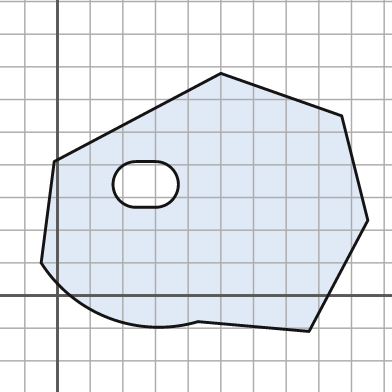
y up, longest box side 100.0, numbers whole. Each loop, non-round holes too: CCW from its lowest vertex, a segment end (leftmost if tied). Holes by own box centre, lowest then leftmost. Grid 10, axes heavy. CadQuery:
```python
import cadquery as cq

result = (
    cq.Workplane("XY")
    .moveTo(77.0, -11.0)
    .lineTo(95.0, 23.0)
    .lineTo(87.0, 55.0)
    .lineTo(50.0, 68.0)
    .lineTo(-1.0, 41.0)
    .lineTo(-5.0, 10.0)
    .threePointArc((16.0, -7.0), (43.0, -8.0))
    .close()
    .moveTo(24.0, 27.0)
    .lineTo(30.0, 27.0)
    .threePointArc((37.0, 34.0), (30.0, 41.0))
    .lineTo(24.0, 41.0)
    .threePointArc((17.0, 34.0), (24.0, 27.0))
    .close()
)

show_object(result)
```